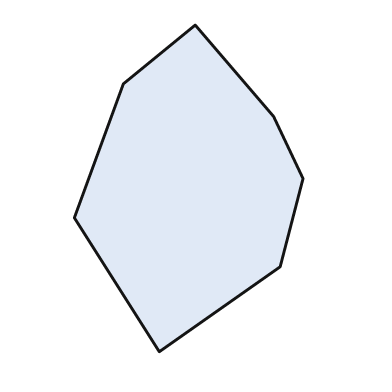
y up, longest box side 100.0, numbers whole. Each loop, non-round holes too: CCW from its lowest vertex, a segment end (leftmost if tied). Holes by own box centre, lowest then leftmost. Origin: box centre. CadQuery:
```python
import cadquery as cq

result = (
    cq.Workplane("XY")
    .moveTo(-9.0, -50.0)
    .lineTo(28.0, -24.0)
    .lineTo(35.0, 3.0)
    .lineTo(26.0, 22.0)
    .lineTo(2.0, 50.0)
    .lineTo(-20.0, 32.0)
    .lineTo(-35.0, -9.0)
    .close()
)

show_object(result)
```